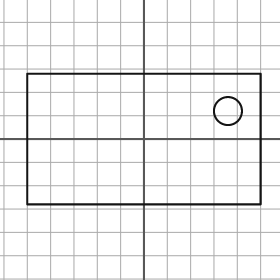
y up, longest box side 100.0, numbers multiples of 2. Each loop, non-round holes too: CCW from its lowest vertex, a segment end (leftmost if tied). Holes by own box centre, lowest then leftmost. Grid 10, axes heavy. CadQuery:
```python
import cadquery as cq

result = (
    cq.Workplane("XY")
    .moveTo(-50.0, -28.0)
    .lineTo(50.0, -28.0)
    .lineTo(50.0, 28.0)
    .lineTo(-50.0, 28.0)
    .close()
    .moveTo(36.0, 12.0)
    .circle(6.0)
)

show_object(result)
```